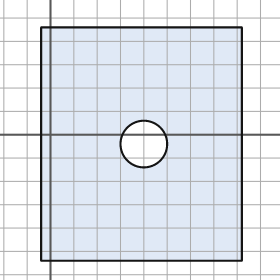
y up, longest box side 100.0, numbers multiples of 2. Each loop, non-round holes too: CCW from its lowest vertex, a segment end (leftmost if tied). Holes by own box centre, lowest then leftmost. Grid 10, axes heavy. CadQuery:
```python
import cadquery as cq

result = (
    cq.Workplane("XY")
    .moveTo(-4.0, -54.0)
    .lineTo(82.0, -54.0)
    .lineTo(82.0, 46.0)
    .lineTo(-4.0, 46.0)
    .close()
    .moveTo(40.0, -4.0)
    .circle(10.0)
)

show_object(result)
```